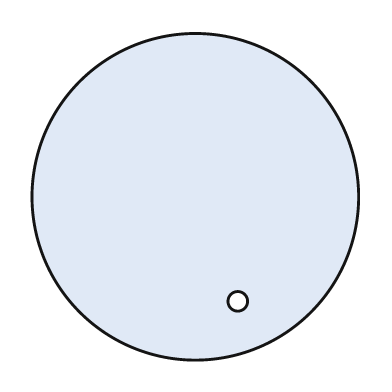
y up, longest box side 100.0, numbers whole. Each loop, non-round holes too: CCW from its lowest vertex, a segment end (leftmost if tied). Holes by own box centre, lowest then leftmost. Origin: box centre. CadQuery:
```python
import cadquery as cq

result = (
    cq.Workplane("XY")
    .moveTo(0.0, 0.0)
    .circle(50.0)
    .moveTo(13.0, -32.0)
    .circle(3.0)
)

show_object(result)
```